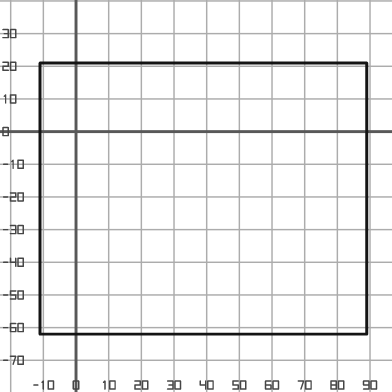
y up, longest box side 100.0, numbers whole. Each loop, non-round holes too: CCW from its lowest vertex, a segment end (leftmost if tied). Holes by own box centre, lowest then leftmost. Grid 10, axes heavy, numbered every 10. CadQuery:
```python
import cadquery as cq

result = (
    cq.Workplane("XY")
    .moveTo(-11.0, -62.0)
    .lineTo(89.0, -62.0)
    .lineTo(89.0, 21.0)
    .lineTo(-11.0, 21.0)
    .close()
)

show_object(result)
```